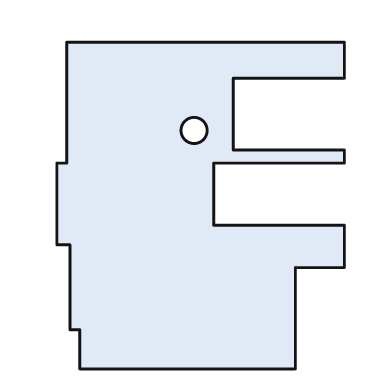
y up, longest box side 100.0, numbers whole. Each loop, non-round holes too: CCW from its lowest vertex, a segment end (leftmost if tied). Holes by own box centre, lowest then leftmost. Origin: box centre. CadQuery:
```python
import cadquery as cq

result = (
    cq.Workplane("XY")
    .moveTo(-37.0, -50.0)
    .lineTo(29.0, -50.0)
    .lineTo(29.0, -19.0)
    .lineTo(44.0, -19.0)
    .lineTo(44.0, -6.0)
    .lineTo(4.0, -6.0)
    .lineTo(4.0, 13.0)
    .lineTo(44.0, 13.0)
    .lineTo(44.0, 17.0)
    .lineTo(10.0, 17.0)
    .lineTo(10.0, 39.0)
    .lineTo(44.0, 39.0)
    .lineTo(44.0, 50.0)
    .lineTo(-41.0, 50.0)
    .lineTo(-41.0, 13.0)
    .lineTo(-44.0, 13.0)
    .lineTo(-44.0, -12.0)
    .lineTo(-40.0, -12.0)
    .lineTo(-40.0, -38.0)
    .lineTo(-37.0, -38.0)
    .close()
    .moveTo(-2.0, 23.0)
    .circle(4.0)
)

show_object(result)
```